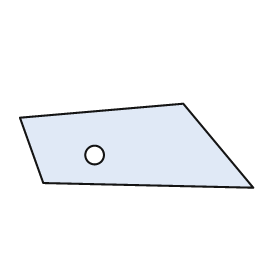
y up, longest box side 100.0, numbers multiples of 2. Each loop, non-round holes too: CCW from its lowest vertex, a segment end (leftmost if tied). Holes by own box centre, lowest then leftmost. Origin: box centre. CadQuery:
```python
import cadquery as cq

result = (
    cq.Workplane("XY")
    .moveTo(50.0, -18.0)
    .lineTo(20.0, 18.0)
    .lineTo(-50.0, 12.0)
    .lineTo(-40.0, -16.0)
    .close()
    .moveTo(-18.0, -4.0)
    .circle(4.0)
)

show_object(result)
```